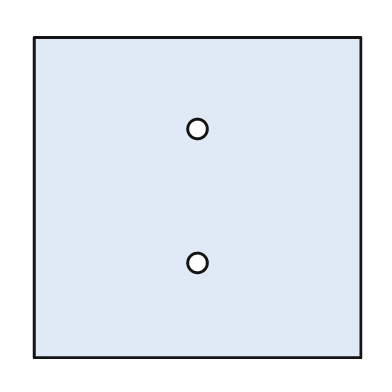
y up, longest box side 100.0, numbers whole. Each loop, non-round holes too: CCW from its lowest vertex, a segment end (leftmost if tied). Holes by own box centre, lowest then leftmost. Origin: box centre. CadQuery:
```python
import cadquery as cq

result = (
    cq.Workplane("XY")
    .moveTo(-50.0, -49.0)
    .lineTo(50.0, -49.0)
    .lineTo(50.0, 49.0)
    .lineTo(-50.0, 49.0)
    .close()
    .moveTo(0.0, -20.0)
    .circle(3.0)
    .moveTo(0.0, 21.0)
    .circle(3.0)
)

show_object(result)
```